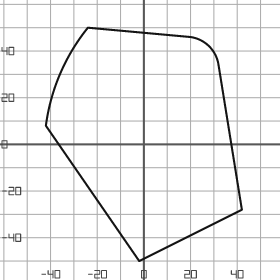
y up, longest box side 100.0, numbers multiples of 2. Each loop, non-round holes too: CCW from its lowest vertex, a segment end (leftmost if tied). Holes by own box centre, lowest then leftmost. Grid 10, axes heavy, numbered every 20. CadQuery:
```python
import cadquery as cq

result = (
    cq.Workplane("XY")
    .moveTo(-2.0, -50.0)
    .lineTo(42.0, -28.0)
    .lineTo(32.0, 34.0)
    .threePointArc((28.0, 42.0), (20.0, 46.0))
    .lineTo(-24.0, 50.0)
    .threePointArc((-36.0, 30.0), (-42.0, 8.0))
    .close()
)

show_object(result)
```